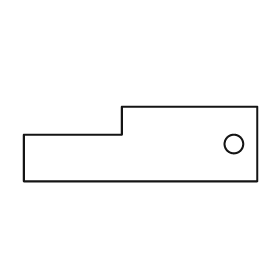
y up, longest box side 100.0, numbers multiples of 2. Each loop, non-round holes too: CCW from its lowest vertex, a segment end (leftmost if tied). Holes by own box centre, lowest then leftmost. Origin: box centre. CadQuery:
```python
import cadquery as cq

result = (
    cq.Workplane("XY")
    .moveTo(-50.0, -16.0)
    .lineTo(50.0, -16.0)
    .lineTo(50.0, 16.0)
    .lineTo(-8.0, 16.0)
    .lineTo(-8.0, 4.0)
    .lineTo(-50.0, 4.0)
    .close()
    .moveTo(40.0, 0.0)
    .circle(4.0)
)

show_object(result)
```